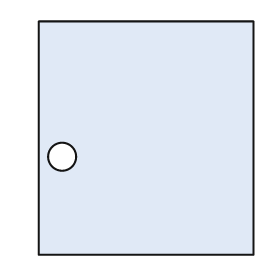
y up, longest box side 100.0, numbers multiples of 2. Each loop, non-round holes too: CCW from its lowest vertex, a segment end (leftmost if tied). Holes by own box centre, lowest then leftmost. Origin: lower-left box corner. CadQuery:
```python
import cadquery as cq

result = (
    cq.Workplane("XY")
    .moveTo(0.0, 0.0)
    .lineTo(92.0, 0.0)
    .lineTo(92.0, 100.0)
    .lineTo(0.0, 100.0)
    .close()
    .moveTo(10.0, 42.0)
    .circle(6.0)
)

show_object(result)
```